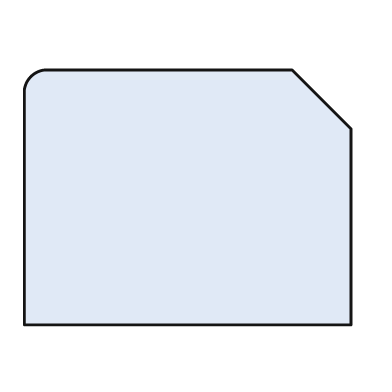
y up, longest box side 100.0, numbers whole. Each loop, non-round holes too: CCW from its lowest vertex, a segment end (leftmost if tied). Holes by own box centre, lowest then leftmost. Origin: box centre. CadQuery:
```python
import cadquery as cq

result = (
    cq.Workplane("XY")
    .moveTo(-50.0, -39.0)
    .lineTo(50.0, -39.0)
    .lineTo(50.0, 21.0)
    .lineTo(32.0, 39.0)
    .lineTo(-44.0, 39.0)
    .threePointArc((-48.0, 37.0), (-50.0, 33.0))
    .close()
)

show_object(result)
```